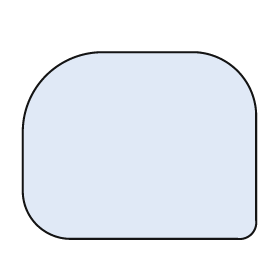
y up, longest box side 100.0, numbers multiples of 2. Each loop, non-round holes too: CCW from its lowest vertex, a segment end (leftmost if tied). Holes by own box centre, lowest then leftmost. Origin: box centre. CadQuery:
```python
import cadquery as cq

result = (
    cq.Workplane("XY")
    .moveTo(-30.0, -40.0)
    .lineTo(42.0, -40.0)
    .threePointArc((48.0, -38.0), (50.0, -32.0))
    .lineTo(50.0, 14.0)
    .threePointArc((42.0, 32.0), (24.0, 40.0))
    .lineTo(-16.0, 40.0)
    .threePointArc((-40.0, 30.0), (-50.0, 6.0))
    .lineTo(-50.0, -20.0)
    .threePointArc((-44.0, -34.0), (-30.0, -40.0))
    .close()
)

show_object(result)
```